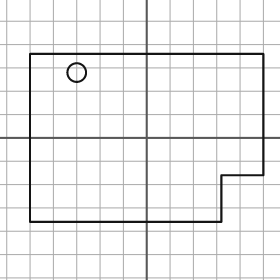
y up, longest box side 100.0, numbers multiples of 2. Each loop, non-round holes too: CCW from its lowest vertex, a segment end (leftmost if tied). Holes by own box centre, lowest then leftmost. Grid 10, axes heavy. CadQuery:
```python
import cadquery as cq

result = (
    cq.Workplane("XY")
    .moveTo(-50.0, -36.0)
    .lineTo(32.0, -36.0)
    .lineTo(32.0, -16.0)
    .lineTo(50.0, -16.0)
    .lineTo(50.0, 36.0)
    .lineTo(-50.0, 36.0)
    .close()
    .moveTo(-30.0, 28.0)
    .circle(4.0)
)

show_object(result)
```